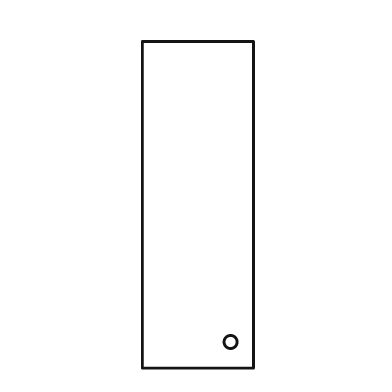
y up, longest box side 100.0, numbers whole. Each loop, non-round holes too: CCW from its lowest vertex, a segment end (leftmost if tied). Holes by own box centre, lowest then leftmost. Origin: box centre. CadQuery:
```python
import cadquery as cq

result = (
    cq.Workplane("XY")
    .moveTo(-17.0, -50.0)
    .lineTo(17.0, -50.0)
    .lineTo(17.0, 50.0)
    .lineTo(-17.0, 50.0)
    .close()
    .moveTo(10.0, -42.0)
    .circle(2.0)
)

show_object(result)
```